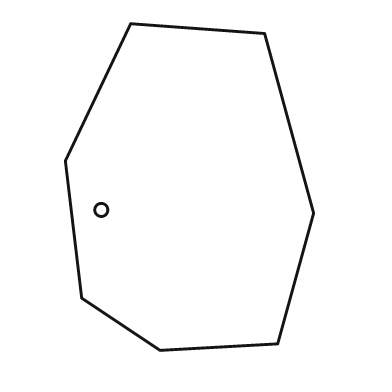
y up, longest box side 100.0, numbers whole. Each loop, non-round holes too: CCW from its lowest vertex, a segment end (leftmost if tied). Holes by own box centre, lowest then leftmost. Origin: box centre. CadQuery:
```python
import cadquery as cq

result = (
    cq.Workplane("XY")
    .moveTo(-9.0, -50.0)
    .lineTo(27.0, -48.0)
    .lineTo(38.0, -8.0)
    .lineTo(23.0, 47.0)
    .lineTo(-18.0, 50.0)
    .lineTo(-38.0, 8.0)
    .lineTo(-33.0, -34.0)
    .close()
    .moveTo(-27.0, -7.0)
    .circle(2.0)
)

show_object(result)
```